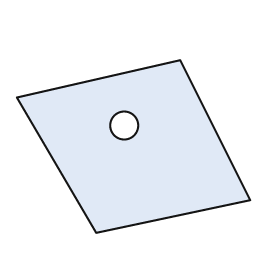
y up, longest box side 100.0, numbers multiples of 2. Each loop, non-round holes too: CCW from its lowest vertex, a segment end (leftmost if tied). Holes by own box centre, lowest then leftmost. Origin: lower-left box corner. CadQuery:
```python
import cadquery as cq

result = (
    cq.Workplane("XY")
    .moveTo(34.0, 0.0)
    .lineTo(100.0, 14.0)
    .lineTo(70.0, 74.0)
    .lineTo(0.0, 58.0)
    .close()
    .moveTo(46.0, 46.0)
    .circle(6.0)
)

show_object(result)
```